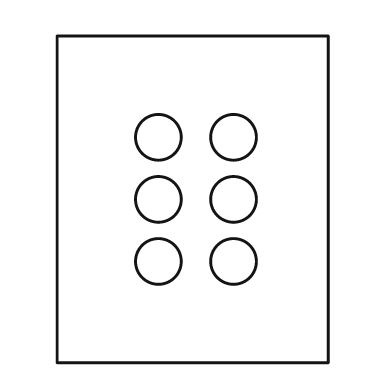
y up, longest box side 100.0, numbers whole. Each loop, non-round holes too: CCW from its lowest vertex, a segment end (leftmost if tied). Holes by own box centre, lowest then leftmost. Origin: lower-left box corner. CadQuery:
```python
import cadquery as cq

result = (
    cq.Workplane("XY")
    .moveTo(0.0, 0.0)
    .lineTo(83.0, 0.0)
    .lineTo(83.0, 100.0)
    .lineTo(0.0, 100.0)
    .close()
    .moveTo(31.0, 31.0)
    .circle(7.0)
    .moveTo(54.0, 31.0)
    .circle(7.0)
    .moveTo(31.0, 50.0)
    .circle(7.0)
    .moveTo(54.0, 50.0)
    .circle(7.0)
    .moveTo(31.0, 69.0)
    .circle(7.0)
    .moveTo(54.0, 69.0)
    .circle(7.0)
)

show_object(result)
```